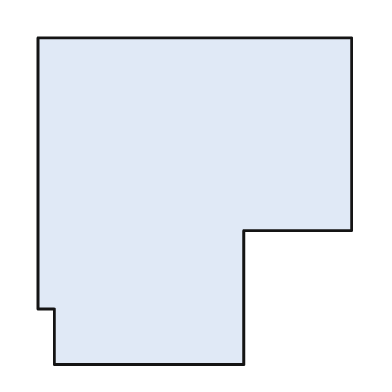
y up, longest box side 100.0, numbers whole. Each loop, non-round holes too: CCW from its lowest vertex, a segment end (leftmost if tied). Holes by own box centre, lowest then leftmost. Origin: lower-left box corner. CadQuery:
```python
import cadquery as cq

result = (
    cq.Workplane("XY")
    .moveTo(5.0, 0.0)
    .lineTo(63.0, 0.0)
    .lineTo(63.0, 41.0)
    .lineTo(96.0, 41.0)
    .lineTo(96.0, 100.0)
    .lineTo(0.0, 100.0)
    .lineTo(0.0, 17.0)
    .lineTo(5.0, 17.0)
    .close()
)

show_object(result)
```